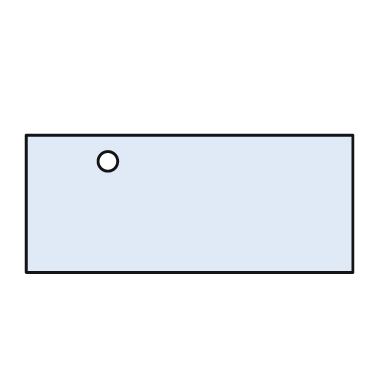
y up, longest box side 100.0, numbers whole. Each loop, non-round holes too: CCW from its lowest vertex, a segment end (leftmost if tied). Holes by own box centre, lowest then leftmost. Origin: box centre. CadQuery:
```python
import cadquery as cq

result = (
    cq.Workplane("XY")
    .moveTo(-50.0, -21.0)
    .lineTo(50.0, -21.0)
    .lineTo(50.0, 21.0)
    .lineTo(-50.0, 21.0)
    .close()
    .moveTo(-25.0, 13.0)
    .circle(3.0)
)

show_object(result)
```